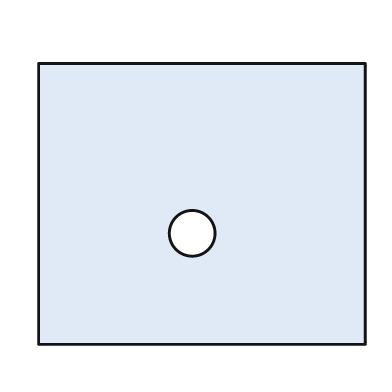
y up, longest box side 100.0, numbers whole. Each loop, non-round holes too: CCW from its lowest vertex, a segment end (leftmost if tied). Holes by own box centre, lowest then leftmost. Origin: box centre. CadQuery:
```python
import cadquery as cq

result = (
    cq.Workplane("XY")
    .moveTo(-50.0, -43.0)
    .lineTo(50.0, -43.0)
    .lineTo(50.0, 43.0)
    .lineTo(-50.0, 43.0)
    .close()
    .moveTo(-3.0, -9.0)
    .circle(7.0)
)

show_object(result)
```